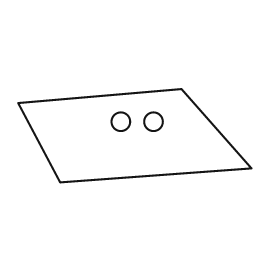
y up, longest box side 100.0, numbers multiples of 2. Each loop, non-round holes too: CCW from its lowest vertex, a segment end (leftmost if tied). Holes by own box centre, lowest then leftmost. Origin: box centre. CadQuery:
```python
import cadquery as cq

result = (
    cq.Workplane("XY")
    .moveTo(-32.0, -20.0)
    .lineTo(50.0, -14.0)
    .lineTo(20.0, 20.0)
    .lineTo(-50.0, 14.0)
    .close()
    .moveTo(-6.0, 6.0)
    .circle(4.0)
    .moveTo(8.0, 6.0)
    .circle(4.0)
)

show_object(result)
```